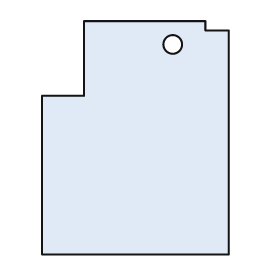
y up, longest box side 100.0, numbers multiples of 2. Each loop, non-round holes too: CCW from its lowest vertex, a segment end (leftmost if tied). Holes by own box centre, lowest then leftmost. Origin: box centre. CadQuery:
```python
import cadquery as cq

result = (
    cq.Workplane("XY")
    .moveTo(-40.0, -50.0)
    .lineTo(40.0, -50.0)
    .lineTo(40.0, 46.0)
    .lineTo(30.0, 46.0)
    .lineTo(30.0, 50.0)
    .lineTo(-22.0, 50.0)
    .lineTo(-22.0, 18.0)
    .lineTo(-40.0, 18.0)
    .close()
    .moveTo(16.0, 40.0)
    .circle(4.0)
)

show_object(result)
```